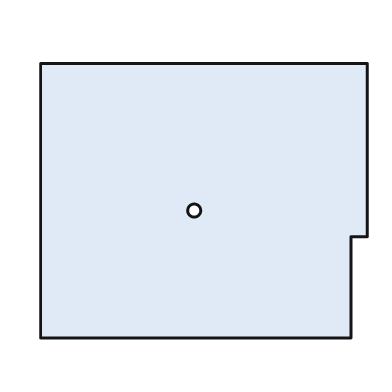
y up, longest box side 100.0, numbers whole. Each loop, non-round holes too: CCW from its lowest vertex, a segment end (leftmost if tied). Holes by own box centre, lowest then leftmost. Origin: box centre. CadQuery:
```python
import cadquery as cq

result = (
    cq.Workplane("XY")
    .moveTo(-50.0, -42.0)
    .lineTo(45.0, -42.0)
    .lineTo(45.0, -11.0)
    .lineTo(50.0, -11.0)
    .lineTo(50.0, 42.0)
    .lineTo(-50.0, 42.0)
    .close()
    .moveTo(-3.0, -3.0)
    .circle(2.0)
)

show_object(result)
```